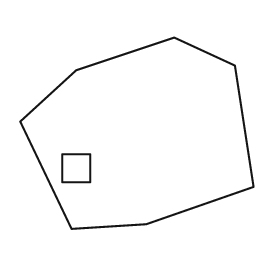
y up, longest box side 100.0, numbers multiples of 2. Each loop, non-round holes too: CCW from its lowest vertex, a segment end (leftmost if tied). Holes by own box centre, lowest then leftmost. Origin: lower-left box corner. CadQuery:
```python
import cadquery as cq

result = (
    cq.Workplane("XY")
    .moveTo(22.0, 0.0)
    .lineTo(54.0, 2.0)
    .lineTo(100.0, 18.0)
    .lineTo(92.0, 70.0)
    .lineTo(66.0, 82.0)
    .lineTo(24.0, 68.0)
    .lineTo(0.0, 46.0)
    .close()
    .moveTo(18.0, 20.0)
    .lineTo(30.0, 20.0)
    .lineTo(30.0, 32.0)
    .lineTo(18.0, 32.0)
    .close()
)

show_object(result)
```